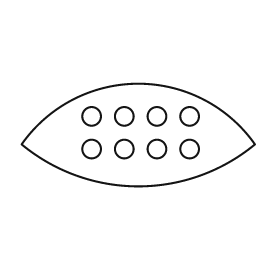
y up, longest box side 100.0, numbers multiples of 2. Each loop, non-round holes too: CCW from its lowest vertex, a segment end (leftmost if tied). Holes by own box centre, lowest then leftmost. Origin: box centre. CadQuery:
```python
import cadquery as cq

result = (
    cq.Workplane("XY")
    .moveTo(-50.0, -4.0)
    .threePointArc((0.0, -22.0), (50.0, -4.0))
    .threePointArc((0.0, 22.0), (-50.0, -4.0))
    .close()
    .moveTo(-20.0, -6.0)
    .circle(4.0)
    .moveTo(-6.0, -6.0)
    .circle(4.0)
    .moveTo(8.0, -6.0)
    .circle(4.0)
    .moveTo(22.0, -6.0)
    .circle(4.0)
    .moveTo(-20.0, 8.0)
    .circle(4.0)
    .moveTo(-6.0, 8.0)
    .circle(4.0)
    .moveTo(8.0, 8.0)
    .circle(4.0)
    .moveTo(22.0, 8.0)
    .circle(4.0)
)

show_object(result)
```